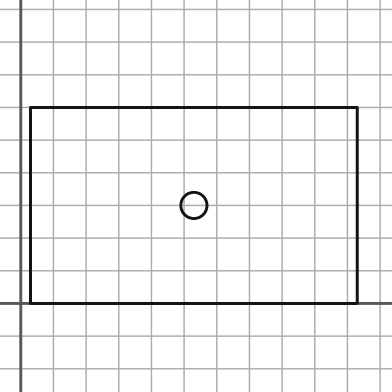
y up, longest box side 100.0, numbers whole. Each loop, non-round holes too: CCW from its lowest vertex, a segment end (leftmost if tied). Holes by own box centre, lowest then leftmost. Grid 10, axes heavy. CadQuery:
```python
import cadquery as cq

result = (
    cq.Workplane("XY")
    .moveTo(3.0, 0.0)
    .lineTo(103.0, 0.0)
    .lineTo(103.0, 60.0)
    .lineTo(3.0, 60.0)
    .close()
    .moveTo(53.0, 30.0)
    .circle(4.0)
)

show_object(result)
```